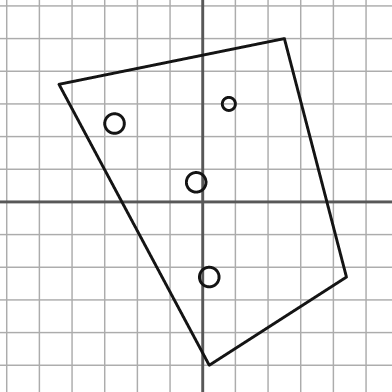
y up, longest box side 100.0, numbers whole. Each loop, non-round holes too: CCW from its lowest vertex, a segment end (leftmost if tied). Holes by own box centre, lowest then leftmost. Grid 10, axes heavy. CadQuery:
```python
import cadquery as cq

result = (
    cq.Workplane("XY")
    .moveTo(2.0, -50.0)
    .lineTo(44.0, -23.0)
    .lineTo(25.0, 50.0)
    .lineTo(-44.0, 36.0)
    .close()
    .moveTo(2.0, -23.0)
    .circle(3.0)
    .moveTo(-2.0, 6.0)
    .circle(3.0)
    .moveTo(-27.0, 24.0)
    .circle(3.0)
    .moveTo(8.0, 30.0)
    .circle(2.0)
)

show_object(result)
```